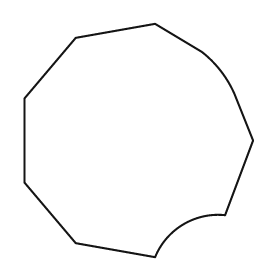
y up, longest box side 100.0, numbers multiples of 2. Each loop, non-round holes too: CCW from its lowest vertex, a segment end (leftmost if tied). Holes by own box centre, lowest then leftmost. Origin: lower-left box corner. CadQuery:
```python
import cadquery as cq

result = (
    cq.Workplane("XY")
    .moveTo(56.0, 0.0)
    .threePointArc((68.0, 14.0), (86.0, 18.0))
    .lineTo(98.0, 50.0)
    .lineTo(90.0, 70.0)
    .threePointArc((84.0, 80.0), (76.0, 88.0))
    .lineTo(56.0, 100.0)
    .lineTo(22.0, 94.0)
    .lineTo(0.0, 68.0)
    .lineTo(0.0, 32.0)
    .lineTo(22.0, 6.0)
    .close()
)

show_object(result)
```